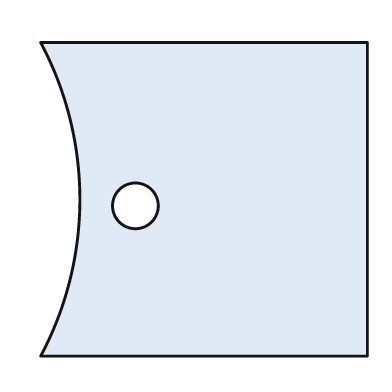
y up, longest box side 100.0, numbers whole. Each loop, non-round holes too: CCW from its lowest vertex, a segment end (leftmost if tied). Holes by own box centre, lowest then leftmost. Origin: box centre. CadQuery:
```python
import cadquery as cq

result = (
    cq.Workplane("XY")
    .moveTo(-50.0, -48.0)
    .lineTo(50.0, -48.0)
    .lineTo(50.0, 48.0)
    .lineTo(-50.0, 48.0)
    .threePointArc((-38.0, 0.0), (-50.0, -48.0))
    .close()
    .moveTo(-21.0, -2.0)
    .circle(7.0)
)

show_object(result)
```